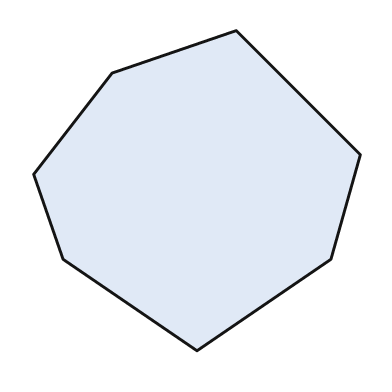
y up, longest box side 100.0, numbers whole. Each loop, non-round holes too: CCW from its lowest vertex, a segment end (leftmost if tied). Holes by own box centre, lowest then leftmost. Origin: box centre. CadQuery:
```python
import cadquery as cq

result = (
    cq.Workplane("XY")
    .moveTo(0.0, -49.0)
    .lineTo(41.0, -21.0)
    .lineTo(50.0, 11.0)
    .lineTo(12.0, 49.0)
    .lineTo(-26.0, 36.0)
    .lineTo(-50.0, 5.0)
    .lineTo(-41.0, -21.0)
    .close()
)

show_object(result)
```